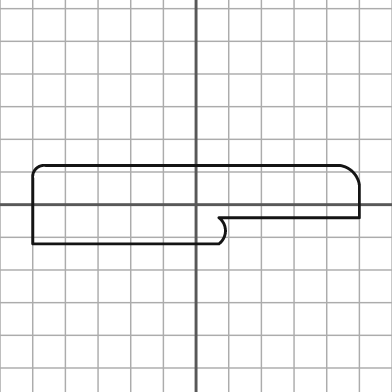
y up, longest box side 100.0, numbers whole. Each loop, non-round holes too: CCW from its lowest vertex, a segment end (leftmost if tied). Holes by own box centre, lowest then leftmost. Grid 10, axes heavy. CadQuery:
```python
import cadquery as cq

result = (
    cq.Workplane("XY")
    .moveTo(-50.0, -12.0)
    .lineTo(7.0, -12.0)
    .threePointArc((9.0, -8.0), (7.0, -4.0))
    .lineTo(50.0, -4.0)
    .lineTo(50.0, 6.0)
    .threePointArc((48.0, 10.0), (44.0, 12.0))
    .lineTo(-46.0, 12.0)
    .threePointArc((-49.0, 11.0), (-50.0, 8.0))
    .close()
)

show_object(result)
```